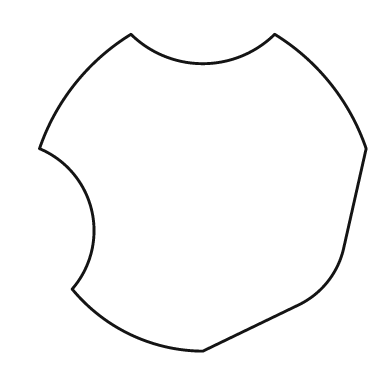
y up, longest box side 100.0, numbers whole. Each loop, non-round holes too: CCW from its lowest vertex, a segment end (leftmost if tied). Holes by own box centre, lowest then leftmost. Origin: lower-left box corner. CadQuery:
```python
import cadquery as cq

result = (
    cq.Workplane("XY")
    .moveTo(50.0, 0.0)
    .lineTo(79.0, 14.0)
    .threePointArc((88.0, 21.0), (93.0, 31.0))
    .lineTo(100.0, 62.0)
    .threePointArc((89.0, 82.0), (72.0, 97.0))
    .threePointArc((50.0, 88.0), (28.0, 97.0))
    .threePointArc((11.0, 82.0), (0.0, 62.0))
    .threePointArc((16.0, 43.0), (10.0, 19.0))
    .threePointArc((28.0, 5.0), (50.0, 0.0))
    .close()
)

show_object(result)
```